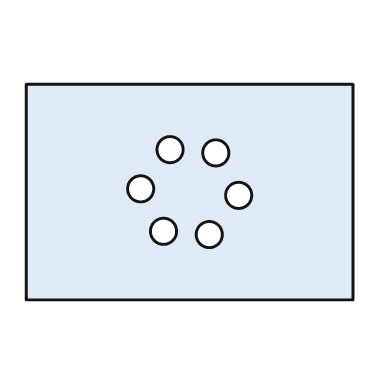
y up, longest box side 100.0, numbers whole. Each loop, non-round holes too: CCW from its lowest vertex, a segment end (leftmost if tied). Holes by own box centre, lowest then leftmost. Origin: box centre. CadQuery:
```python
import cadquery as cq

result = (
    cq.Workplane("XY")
    .moveTo(-50.0, -33.0)
    .lineTo(50.0, -33.0)
    .lineTo(50.0, 33.0)
    .lineTo(-50.0, 33.0)
    .close()
    .moveTo(6.0, -13.0)
    .circle(4.0)
    .moveTo(-8.0, -12.0)
    .circle(4.0)
    .moveTo(15.0, -1.0)
    .circle(4.0)
    .moveTo(-15.0, 1.0)
    .circle(4.0)
    .moveTo(8.0, 12.0)
    .circle(4.0)
    .moveTo(-6.0, 13.0)
    .circle(4.0)
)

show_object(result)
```